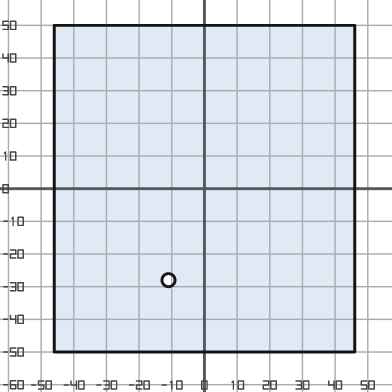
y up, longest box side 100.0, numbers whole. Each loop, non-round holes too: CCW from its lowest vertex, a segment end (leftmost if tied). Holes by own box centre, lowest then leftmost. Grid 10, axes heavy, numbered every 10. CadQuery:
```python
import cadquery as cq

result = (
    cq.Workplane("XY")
    .moveTo(-46.0, -50.0)
    .lineTo(46.0, -50.0)
    .lineTo(46.0, 50.0)
    .lineTo(-46.0, 50.0)
    .close()
    .moveTo(-11.0, -28.0)
    .circle(2.0)
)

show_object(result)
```